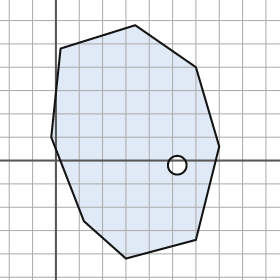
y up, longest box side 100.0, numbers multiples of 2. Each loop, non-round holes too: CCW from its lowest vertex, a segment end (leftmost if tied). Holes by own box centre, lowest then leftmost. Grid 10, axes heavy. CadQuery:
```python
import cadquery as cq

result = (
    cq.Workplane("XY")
    .moveTo(30.0, -42.0)
    .lineTo(60.0, -34.0)
    .lineTo(70.0, 6.0)
    .lineTo(60.0, 40.0)
    .lineTo(34.0, 58.0)
    .lineTo(2.0, 48.0)
    .lineTo(-2.0, 10.0)
    .lineTo(12.0, -26.0)
    .close()
    .moveTo(52.0, -2.0)
    .circle(4.0)
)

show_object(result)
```